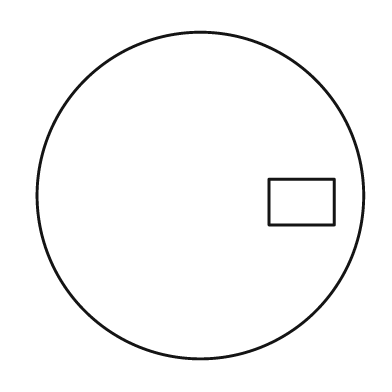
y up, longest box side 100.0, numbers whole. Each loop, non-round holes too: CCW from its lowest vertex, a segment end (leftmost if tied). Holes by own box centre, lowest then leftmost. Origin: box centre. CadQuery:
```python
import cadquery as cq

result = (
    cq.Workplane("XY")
    .moveTo(0.0, 0.0)
    .circle(50.0)
    .moveTo(21.0, -9.0)
    .lineTo(41.0, -9.0)
    .lineTo(41.0, 5.0)
    .lineTo(21.0, 5.0)
    .close()
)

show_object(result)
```